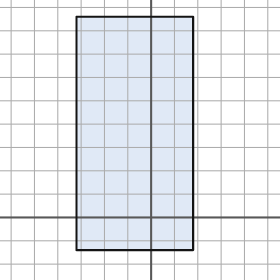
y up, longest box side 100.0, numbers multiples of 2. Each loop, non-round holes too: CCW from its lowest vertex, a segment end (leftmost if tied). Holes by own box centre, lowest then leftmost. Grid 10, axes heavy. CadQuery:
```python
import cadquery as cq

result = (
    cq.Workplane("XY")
    .moveTo(-32.0, -14.0)
    .lineTo(18.0, -14.0)
    .lineTo(18.0, 86.0)
    .lineTo(-32.0, 86.0)
    .close()
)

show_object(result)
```